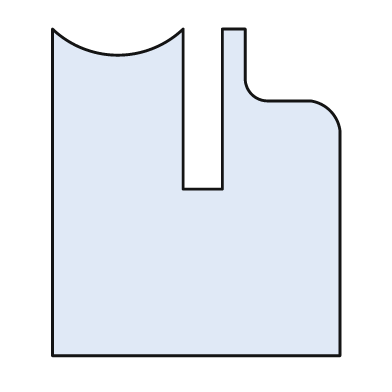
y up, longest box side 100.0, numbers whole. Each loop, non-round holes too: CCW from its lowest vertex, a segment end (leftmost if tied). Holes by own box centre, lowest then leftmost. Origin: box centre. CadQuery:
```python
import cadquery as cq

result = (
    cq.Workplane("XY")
    .moveTo(-44.0, -50.0)
    .lineTo(44.0, -50.0)
    .lineTo(44.0, 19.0)
    .threePointArc((41.0, 25.0), (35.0, 28.0))
    .lineTo(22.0, 28.0)
    .threePointArc((17.0, 30.0), (15.0, 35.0))
    .lineTo(15.0, 50.0)
    .lineTo(8.0, 50.0)
    .lineTo(8.0, 1.0)
    .lineTo(-4.0, 1.0)
    .lineTo(-4.0, 50.0)
    .threePointArc((-24.0, 42.0), (-44.0, 50.0))
    .close()
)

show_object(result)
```